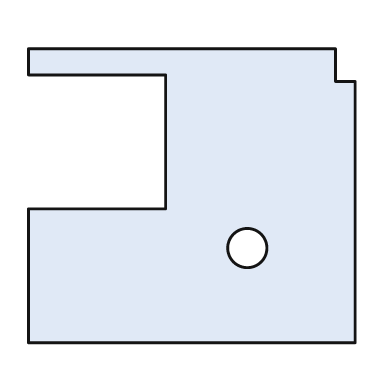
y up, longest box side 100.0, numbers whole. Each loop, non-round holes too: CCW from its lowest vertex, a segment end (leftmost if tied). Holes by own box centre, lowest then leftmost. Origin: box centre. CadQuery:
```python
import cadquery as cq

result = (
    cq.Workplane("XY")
    .moveTo(-50.0, -45.0)
    .lineTo(50.0, -45.0)
    .lineTo(50.0, 35.0)
    .lineTo(44.0, 35.0)
    .lineTo(44.0, 45.0)
    .lineTo(-50.0, 45.0)
    .lineTo(-50.0, 37.0)
    .lineTo(-8.0, 37.0)
    .lineTo(-8.0, -4.0)
    .lineTo(-50.0, -4.0)
    .close()
    .moveTo(17.0, -16.0)
    .circle(6.0)
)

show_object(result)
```